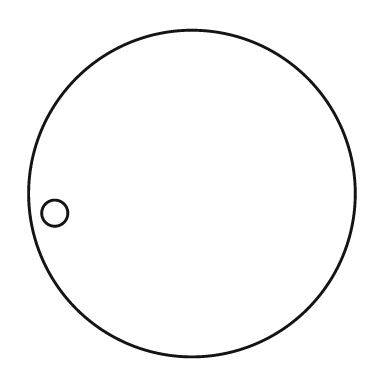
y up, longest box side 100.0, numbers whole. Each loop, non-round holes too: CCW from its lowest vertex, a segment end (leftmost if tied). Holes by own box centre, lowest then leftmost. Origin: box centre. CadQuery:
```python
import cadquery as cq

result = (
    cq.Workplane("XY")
    .moveTo(0.0, 0.0)
    .circle(50.0)
    .moveTo(-42.0, -6.0)
    .circle(4.0)
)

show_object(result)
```